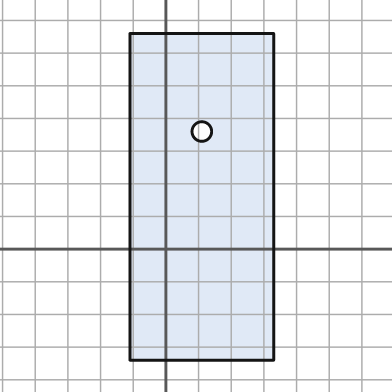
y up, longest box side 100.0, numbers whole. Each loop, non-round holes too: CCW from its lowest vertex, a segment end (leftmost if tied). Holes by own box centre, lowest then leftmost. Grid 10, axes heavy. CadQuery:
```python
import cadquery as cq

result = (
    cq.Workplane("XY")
    .moveTo(-11.0, -34.0)
    .lineTo(33.0, -34.0)
    .lineTo(33.0, 66.0)
    .lineTo(-11.0, 66.0)
    .close()
    .moveTo(11.0, 36.0)
    .circle(3.0)
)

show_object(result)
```